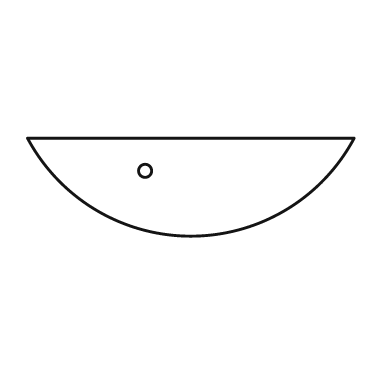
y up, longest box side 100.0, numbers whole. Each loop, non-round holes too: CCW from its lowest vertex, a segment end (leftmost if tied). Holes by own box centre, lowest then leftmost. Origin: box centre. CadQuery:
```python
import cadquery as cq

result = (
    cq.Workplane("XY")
    .moveTo(-50.0, 15.0)
    .threePointArc((0.0, -15.0), (50.0, 15.0))
    .close()
    .moveTo(-14.0, 5.0)
    .circle(2.0)
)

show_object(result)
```